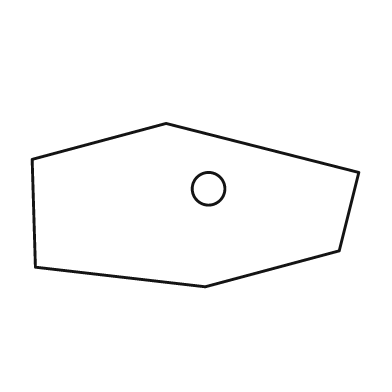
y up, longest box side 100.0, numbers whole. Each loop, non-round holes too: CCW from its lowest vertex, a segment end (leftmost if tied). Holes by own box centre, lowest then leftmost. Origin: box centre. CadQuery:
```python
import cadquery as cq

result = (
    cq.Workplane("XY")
    .moveTo(3.0, -25.0)
    .lineTo(44.0, -14.0)
    .lineTo(50.0, 10.0)
    .lineTo(-9.0, 25.0)
    .lineTo(-50.0, 14.0)
    .lineTo(-49.0, -19.0)
    .close()
    .moveTo(4.0, 5.0)
    .circle(5.0)
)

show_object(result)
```